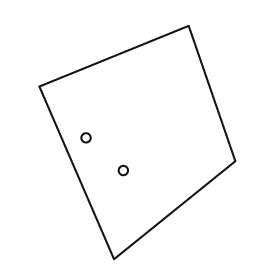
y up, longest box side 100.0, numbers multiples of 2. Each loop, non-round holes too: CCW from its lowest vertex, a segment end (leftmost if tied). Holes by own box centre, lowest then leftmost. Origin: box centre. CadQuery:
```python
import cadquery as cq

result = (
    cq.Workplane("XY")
    .moveTo(-10.0, -50.0)
    .lineTo(42.0, -8.0)
    .lineTo(22.0, 50.0)
    .lineTo(-42.0, 24.0)
    .close()
    .moveTo(-6.0, -12.0)
    .circle(2.0)
    .moveTo(-22.0, 2.0)
    .circle(2.0)
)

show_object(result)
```